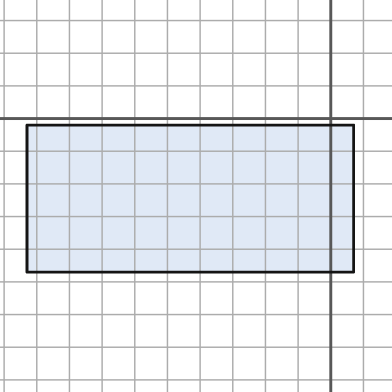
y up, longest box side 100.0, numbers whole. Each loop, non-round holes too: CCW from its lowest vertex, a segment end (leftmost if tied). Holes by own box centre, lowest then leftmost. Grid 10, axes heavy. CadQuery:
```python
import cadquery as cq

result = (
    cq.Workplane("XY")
    .moveTo(-93.0, -47.0)
    .lineTo(7.0, -47.0)
    .lineTo(7.0, -2.0)
    .lineTo(-93.0, -2.0)
    .close()
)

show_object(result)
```